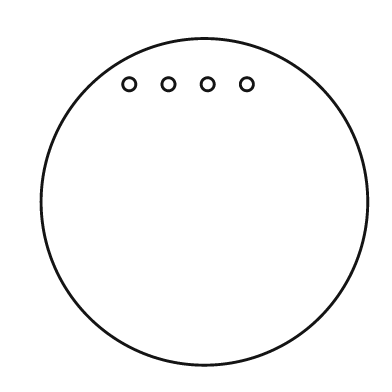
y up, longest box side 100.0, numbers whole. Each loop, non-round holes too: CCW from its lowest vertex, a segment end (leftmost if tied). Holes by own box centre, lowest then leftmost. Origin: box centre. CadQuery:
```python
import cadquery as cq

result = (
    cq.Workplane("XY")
    .moveTo(0.0, 0.0)
    .circle(50.0)
    .moveTo(-23.0, 36.0)
    .circle(2.0)
    .moveTo(-11.0, 36.0)
    .circle(2.0)
    .moveTo(1.0, 36.0)
    .circle(2.0)
    .moveTo(13.0, 36.0)
    .circle(2.0)
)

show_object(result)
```